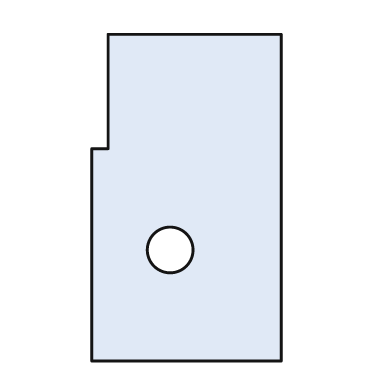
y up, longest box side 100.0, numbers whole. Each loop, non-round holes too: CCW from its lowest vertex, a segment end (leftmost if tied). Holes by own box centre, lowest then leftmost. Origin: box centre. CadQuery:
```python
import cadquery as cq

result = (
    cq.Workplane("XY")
    .moveTo(-29.0, -50.0)
    .lineTo(29.0, -50.0)
    .lineTo(29.0, 50.0)
    .lineTo(-24.0, 50.0)
    .lineTo(-24.0, 15.0)
    .lineTo(-29.0, 15.0)
    .close()
    .moveTo(-5.0, -16.0)
    .circle(7.0)
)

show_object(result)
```